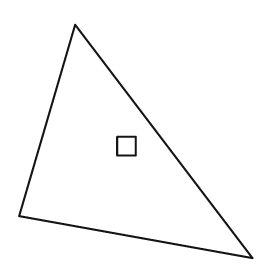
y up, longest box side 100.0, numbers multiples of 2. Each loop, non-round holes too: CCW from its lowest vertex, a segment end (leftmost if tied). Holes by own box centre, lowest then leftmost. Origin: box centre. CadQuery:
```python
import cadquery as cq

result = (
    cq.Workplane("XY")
    .moveTo(50.0, -50.0)
    .lineTo(-26.0, 50.0)
    .lineTo(-50.0, -32.0)
    .close()
    .moveTo(-8.0, -6.0)
    .lineTo(0.0, -6.0)
    .lineTo(0.0, 2.0)
    .lineTo(-8.0, 2.0)
    .close()
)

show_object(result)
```